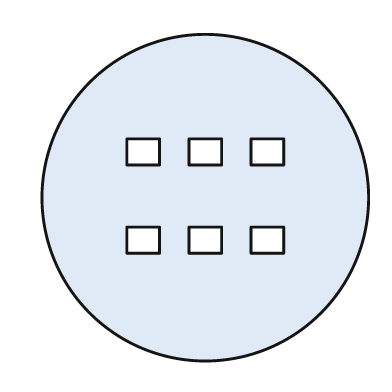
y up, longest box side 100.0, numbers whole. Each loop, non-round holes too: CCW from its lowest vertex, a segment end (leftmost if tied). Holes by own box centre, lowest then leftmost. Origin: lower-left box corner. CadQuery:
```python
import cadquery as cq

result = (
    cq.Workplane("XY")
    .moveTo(50.0, 50.0)
    .circle(50.0)
    .moveTo(26.0, 33.0)
    .lineTo(36.0, 33.0)
    .lineTo(36.0, 41.0)
    .lineTo(26.0, 41.0)
    .close()
    .moveTo(45.0, 33.0)
    .lineTo(55.0, 33.0)
    .lineTo(55.0, 41.0)
    .lineTo(45.0, 41.0)
    .close()
    .moveTo(64.0, 33.0)
    .lineTo(74.0, 33.0)
    .lineTo(74.0, 41.0)
    .lineTo(64.0, 41.0)
    .close()
    .moveTo(26.0, 60.0)
    .lineTo(36.0, 60.0)
    .lineTo(36.0, 68.0)
    .lineTo(26.0, 68.0)
    .close()
    .moveTo(45.0, 60.0)
    .lineTo(55.0, 60.0)
    .lineTo(55.0, 68.0)
    .lineTo(45.0, 68.0)
    .close()
    .moveTo(64.0, 60.0)
    .lineTo(74.0, 60.0)
    .lineTo(74.0, 68.0)
    .lineTo(64.0, 68.0)
    .close()
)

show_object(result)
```